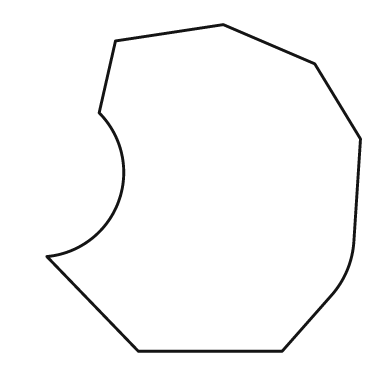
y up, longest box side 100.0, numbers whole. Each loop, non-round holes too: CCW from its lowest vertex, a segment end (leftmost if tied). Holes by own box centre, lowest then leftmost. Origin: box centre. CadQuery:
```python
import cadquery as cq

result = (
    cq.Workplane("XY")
    .moveTo(-20.0, -50.0)
    .lineTo(24.0, -50.0)
    .lineTo(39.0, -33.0)
    .threePointArc((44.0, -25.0), (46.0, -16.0))
    .lineTo(48.0, 15.0)
    .lineTo(34.0, 38.0)
    .lineTo(6.0, 50.0)
    .lineTo(-27.0, 45.0)
    .lineTo(-32.0, 23.0)
    .threePointArc((-26.0, -4.0), (-48.0, -21.0))
    .close()
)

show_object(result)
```